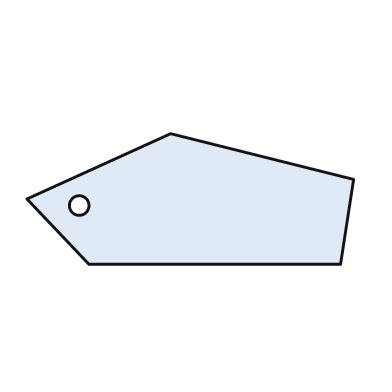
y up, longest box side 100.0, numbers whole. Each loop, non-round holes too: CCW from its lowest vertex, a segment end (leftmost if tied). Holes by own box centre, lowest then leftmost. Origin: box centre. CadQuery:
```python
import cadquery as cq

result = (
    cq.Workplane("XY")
    .moveTo(-31.0, -20.0)
    .lineTo(46.0, -20.0)
    .lineTo(50.0, 6.0)
    .lineTo(-6.0, 20.0)
    .lineTo(-50.0, 0.0)
    .close()
    .moveTo(-34.0, -2.0)
    .circle(3.0)
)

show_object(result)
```